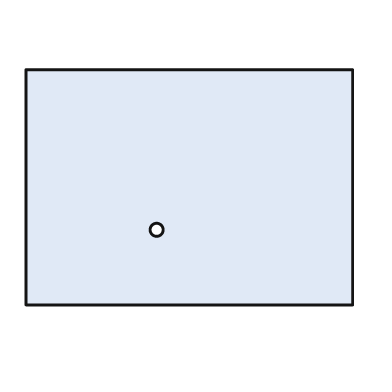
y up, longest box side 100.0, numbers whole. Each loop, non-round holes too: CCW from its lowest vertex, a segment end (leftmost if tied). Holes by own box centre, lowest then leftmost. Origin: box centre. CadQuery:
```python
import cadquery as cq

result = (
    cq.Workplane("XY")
    .moveTo(-50.0, -36.0)
    .lineTo(50.0, -36.0)
    .lineTo(50.0, 36.0)
    .lineTo(-50.0, 36.0)
    .close()
    .moveTo(-10.0, -13.0)
    .circle(2.0)
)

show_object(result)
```